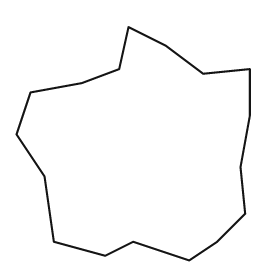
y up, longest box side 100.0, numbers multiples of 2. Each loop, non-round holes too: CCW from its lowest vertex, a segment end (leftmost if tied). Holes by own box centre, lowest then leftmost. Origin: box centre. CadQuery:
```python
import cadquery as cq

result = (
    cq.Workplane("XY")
    .moveTo(24.0, -50.0)
    .lineTo(36.0, -42.0)
    .lineTo(48.0, -30.0)
    .lineTo(46.0, -10.0)
    .lineTo(50.0, 12.0)
    .lineTo(50.0, 32.0)
    .lineTo(30.0, 30.0)
    .lineTo(14.0, 42.0)
    .lineTo(-2.0, 50.0)
    .lineTo(-6.0, 32.0)
    .lineTo(-22.0, 26.0)
    .lineTo(-44.0, 22.0)
    .lineTo(-50.0, 4.0)
    .lineTo(-38.0, -14.0)
    .lineTo(-34.0, -42.0)
    .lineTo(-12.0, -48.0)
    .lineTo(0.0, -42.0)
    .close()
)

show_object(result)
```